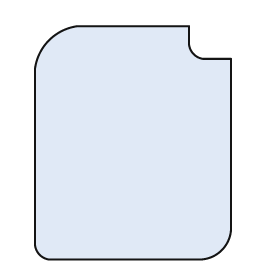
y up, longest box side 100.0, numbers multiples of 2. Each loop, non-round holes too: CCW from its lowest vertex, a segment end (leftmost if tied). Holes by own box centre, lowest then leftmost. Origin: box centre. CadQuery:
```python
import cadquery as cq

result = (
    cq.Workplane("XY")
    .moveTo(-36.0, -50.0)
    .lineTo(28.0, -50.0)
    .threePointArc((38.0, -46.0), (42.0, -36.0))
    .lineTo(42.0, 36.0)
    .lineTo(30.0, 36.0)
    .threePointArc((26.0, 38.0), (24.0, 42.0))
    .lineTo(24.0, 50.0)
    .lineTo(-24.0, 50.0)
    .threePointArc((-36.0, 44.0), (-42.0, 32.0))
    .lineTo(-42.0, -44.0)
    .threePointArc((-40.0, -48.0), (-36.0, -50.0))
    .close()
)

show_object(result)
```